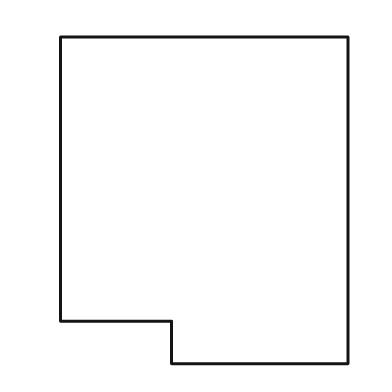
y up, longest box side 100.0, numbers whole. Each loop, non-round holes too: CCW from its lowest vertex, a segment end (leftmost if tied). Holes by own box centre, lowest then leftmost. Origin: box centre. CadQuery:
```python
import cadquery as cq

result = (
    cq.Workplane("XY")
    .moveTo(-10.0, -50.0)
    .lineTo(44.0, -50.0)
    .lineTo(44.0, 50.0)
    .lineTo(-44.0, 50.0)
    .lineTo(-44.0, -37.0)
    .lineTo(-10.0, -37.0)
    .close()
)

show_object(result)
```